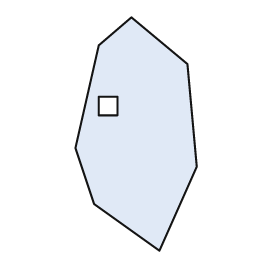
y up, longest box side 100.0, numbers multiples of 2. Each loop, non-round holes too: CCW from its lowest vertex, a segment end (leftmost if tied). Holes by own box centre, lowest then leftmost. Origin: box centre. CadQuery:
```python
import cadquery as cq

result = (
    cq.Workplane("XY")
    .moveTo(10.0, -50.0)
    .lineTo(26.0, -14.0)
    .lineTo(22.0, 30.0)
    .lineTo(-2.0, 50.0)
    .lineTo(-16.0, 38.0)
    .lineTo(-26.0, -6.0)
    .lineTo(-18.0, -30.0)
    .close()
    .moveTo(-16.0, 8.0)
    .lineTo(-8.0, 8.0)
    .lineTo(-8.0, 16.0)
    .lineTo(-16.0, 16.0)
    .close()
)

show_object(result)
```